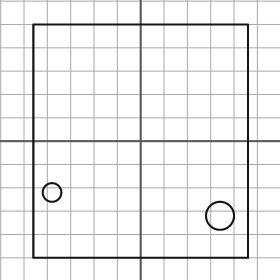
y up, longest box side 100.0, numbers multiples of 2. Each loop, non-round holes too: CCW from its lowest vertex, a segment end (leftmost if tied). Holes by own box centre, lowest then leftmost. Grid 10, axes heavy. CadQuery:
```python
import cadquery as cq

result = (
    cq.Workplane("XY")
    .moveTo(-46.0, -50.0)
    .lineTo(46.0, -50.0)
    .lineTo(46.0, 50.0)
    .lineTo(-46.0, 50.0)
    .close()
    .moveTo(34.0, -32.0)
    .circle(6.0)
    .moveTo(-38.0, -22.0)
    .circle(4.0)
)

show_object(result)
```